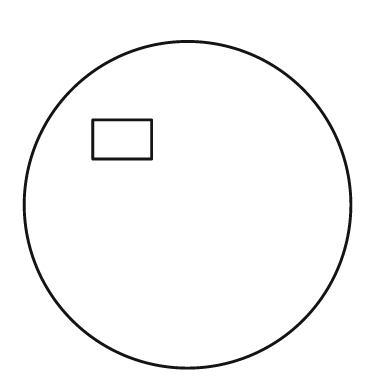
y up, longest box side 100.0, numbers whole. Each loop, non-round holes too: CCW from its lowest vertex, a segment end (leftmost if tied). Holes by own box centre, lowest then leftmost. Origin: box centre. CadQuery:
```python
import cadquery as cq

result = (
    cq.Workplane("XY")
    .moveTo(0.0, 0.0)
    .circle(50.0)
    .moveTo(-29.0, 14.0)
    .lineTo(-11.0, 14.0)
    .lineTo(-11.0, 26.0)
    .lineTo(-29.0, 26.0)
    .close()
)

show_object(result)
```